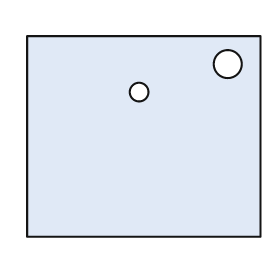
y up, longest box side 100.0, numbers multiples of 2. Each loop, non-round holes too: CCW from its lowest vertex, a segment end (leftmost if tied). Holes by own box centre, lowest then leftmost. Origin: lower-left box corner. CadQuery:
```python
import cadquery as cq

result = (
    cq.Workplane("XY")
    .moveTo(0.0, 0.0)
    .lineTo(100.0, 0.0)
    .lineTo(100.0, 86.0)
    .lineTo(0.0, 86.0)
    .close()
    .moveTo(48.0, 62.0)
    .circle(4.0)
    .moveTo(86.0, 74.0)
    .circle(6.0)
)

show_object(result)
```